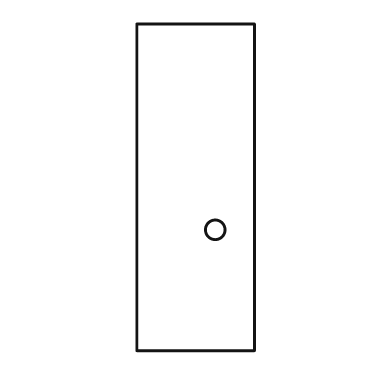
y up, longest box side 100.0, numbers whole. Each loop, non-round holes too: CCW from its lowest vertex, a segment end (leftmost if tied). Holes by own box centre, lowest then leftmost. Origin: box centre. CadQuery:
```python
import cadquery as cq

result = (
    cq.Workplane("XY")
    .moveTo(-18.0, -50.0)
    .lineTo(18.0, -50.0)
    .lineTo(18.0, 50.0)
    .lineTo(-18.0, 50.0)
    .close()
    .moveTo(6.0, -13.0)
    .circle(3.0)
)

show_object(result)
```